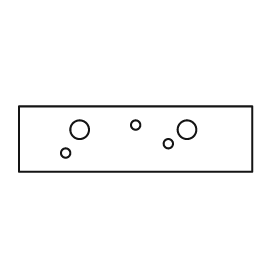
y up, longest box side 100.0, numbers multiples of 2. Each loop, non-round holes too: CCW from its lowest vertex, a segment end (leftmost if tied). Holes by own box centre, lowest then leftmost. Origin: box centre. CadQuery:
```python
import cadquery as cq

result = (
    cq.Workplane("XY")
    .moveTo(-50.0, -14.0)
    .lineTo(50.0, -14.0)
    .lineTo(50.0, 14.0)
    .lineTo(-50.0, 14.0)
    .close()
    .moveTo(-30.0, -6.0)
    .circle(2.0)
    .moveTo(14.0, -2.0)
    .circle(2.0)
    .moveTo(-24.0, 4.0)
    .circle(4.0)
    .moveTo(22.0, 4.0)
    .circle(4.0)
    .moveTo(0.0, 6.0)
    .circle(2.0)
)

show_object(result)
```